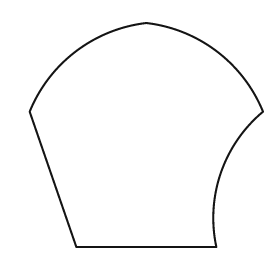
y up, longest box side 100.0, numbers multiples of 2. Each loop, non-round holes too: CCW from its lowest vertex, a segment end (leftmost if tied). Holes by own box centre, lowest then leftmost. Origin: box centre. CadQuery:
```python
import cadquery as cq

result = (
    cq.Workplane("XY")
    .moveTo(-30.0, -48.0)
    .lineTo(30.0, -48.0)
    .threePointArc((32.0, -16.0), (50.0, 10.0))
    .threePointArc((30.0, 36.0), (0.0, 48.0))
    .threePointArc((-30.0, 36.0), (-50.0, 10.0))
    .close()
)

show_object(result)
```